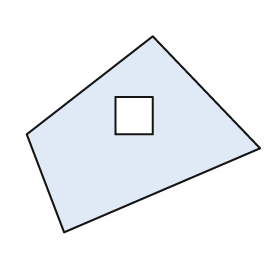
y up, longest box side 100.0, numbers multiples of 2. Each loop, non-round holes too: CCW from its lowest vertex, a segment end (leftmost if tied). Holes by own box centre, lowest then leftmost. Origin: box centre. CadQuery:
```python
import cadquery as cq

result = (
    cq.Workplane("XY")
    .moveTo(-34.0, -42.0)
    .lineTo(50.0, -6.0)
    .lineTo(4.0, 42.0)
    .lineTo(-50.0, 0.0)
    .close()
    .moveTo(-12.0, 0.0)
    .lineTo(4.0, 0.0)
    .lineTo(4.0, 16.0)
    .lineTo(-12.0, 16.0)
    .close()
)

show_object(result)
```